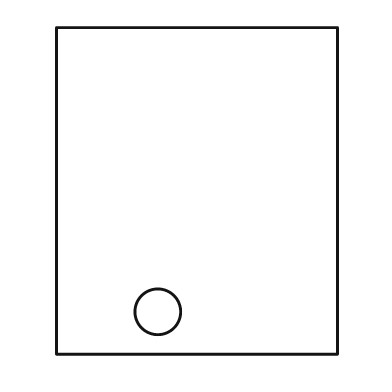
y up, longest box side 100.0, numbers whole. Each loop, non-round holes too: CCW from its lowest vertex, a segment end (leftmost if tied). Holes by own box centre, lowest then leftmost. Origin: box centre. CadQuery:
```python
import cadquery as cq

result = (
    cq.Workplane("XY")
    .moveTo(-43.0, -50.0)
    .lineTo(43.0, -50.0)
    .lineTo(43.0, 50.0)
    .lineTo(-43.0, 50.0)
    .close()
    .moveTo(-12.0, -37.0)
    .circle(7.0)
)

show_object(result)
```